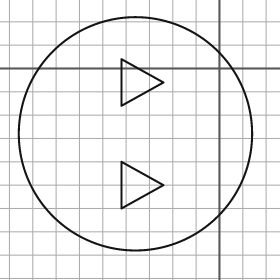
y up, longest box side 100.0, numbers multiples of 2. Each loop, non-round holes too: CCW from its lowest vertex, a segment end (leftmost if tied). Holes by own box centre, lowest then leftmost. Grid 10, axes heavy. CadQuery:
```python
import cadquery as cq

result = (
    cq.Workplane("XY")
    .moveTo(-36.0, -28.0)
    .circle(50.0)
    .moveTo(-42.0, -60.0)
    .lineTo(-24.0, -50.0)
    .lineTo(-42.0, -40.0)
    .close()
    .moveTo(-42.0, -16.0)
    .lineTo(-24.0, -6.0)
    .lineTo(-42.0, 4.0)
    .close()
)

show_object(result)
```